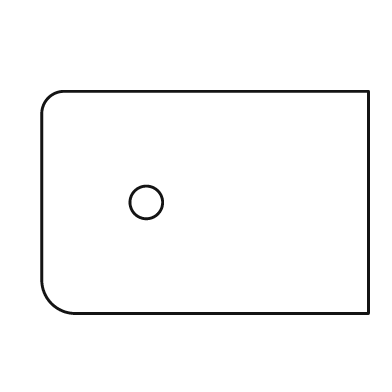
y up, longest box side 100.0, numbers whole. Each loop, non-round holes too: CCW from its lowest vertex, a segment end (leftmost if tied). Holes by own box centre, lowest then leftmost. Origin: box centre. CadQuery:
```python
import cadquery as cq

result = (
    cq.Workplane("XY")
    .moveTo(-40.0, -34.0)
    .lineTo(50.0, -34.0)
    .lineTo(50.0, 34.0)
    .lineTo(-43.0, 34.0)
    .threePointArc((-48.0, 32.0), (-50.0, 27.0))
    .lineTo(-50.0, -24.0)
    .threePointArc((-47.0, -31.0), (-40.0, -34.0))
    .close()
    .moveTo(-18.0, 0.0)
    .circle(5.0)
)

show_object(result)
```